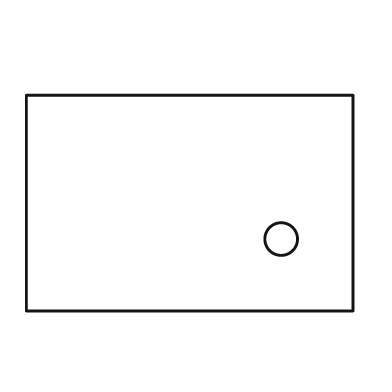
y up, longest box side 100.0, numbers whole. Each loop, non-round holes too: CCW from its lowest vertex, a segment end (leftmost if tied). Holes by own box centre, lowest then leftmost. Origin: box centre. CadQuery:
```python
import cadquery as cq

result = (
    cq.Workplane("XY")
    .moveTo(-50.0, -33.0)
    .lineTo(50.0, -33.0)
    .lineTo(50.0, 33.0)
    .lineTo(-50.0, 33.0)
    .close()
    .moveTo(28.0, -11.0)
    .circle(5.0)
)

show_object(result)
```